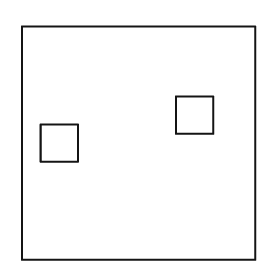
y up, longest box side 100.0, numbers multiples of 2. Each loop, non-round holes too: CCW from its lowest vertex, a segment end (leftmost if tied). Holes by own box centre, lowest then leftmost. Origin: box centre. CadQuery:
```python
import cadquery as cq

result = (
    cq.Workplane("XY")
    .moveTo(-50.0, -50.0)
    .lineTo(50.0, -50.0)
    .lineTo(50.0, 50.0)
    .lineTo(-50.0, 50.0)
    .close()
    .moveTo(-42.0, -8.0)
    .lineTo(-26.0, -8.0)
    .lineTo(-26.0, 8.0)
    .lineTo(-42.0, 8.0)
    .close()
    .moveTo(16.0, 4.0)
    .lineTo(32.0, 4.0)
    .lineTo(32.0, 20.0)
    .lineTo(16.0, 20.0)
    .close()
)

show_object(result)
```